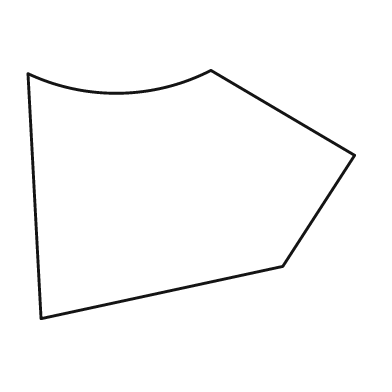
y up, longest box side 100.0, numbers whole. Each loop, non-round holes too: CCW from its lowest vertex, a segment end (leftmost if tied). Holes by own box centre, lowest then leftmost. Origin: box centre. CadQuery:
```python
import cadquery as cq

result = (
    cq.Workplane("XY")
    .moveTo(-46.0, -38.0)
    .lineTo(28.0, -22.0)
    .lineTo(50.0, 12.0)
    .lineTo(6.0, 38.0)
    .threePointArc((-22.0, 31.0), (-50.0, 37.0))
    .close()
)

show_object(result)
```